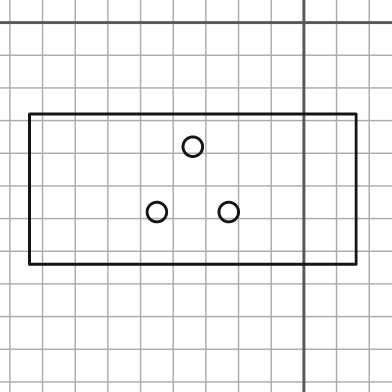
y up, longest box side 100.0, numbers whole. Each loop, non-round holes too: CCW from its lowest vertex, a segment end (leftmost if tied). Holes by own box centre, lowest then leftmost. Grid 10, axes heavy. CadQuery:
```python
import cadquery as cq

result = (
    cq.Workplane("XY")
    .moveTo(-84.0, -74.0)
    .lineTo(16.0, -74.0)
    .lineTo(16.0, -28.0)
    .lineTo(-84.0, -28.0)
    .close()
    .moveTo(-45.0, -58.0)
    .circle(3.0)
    .moveTo(-23.0, -58.0)
    .circle(3.0)
    .moveTo(-34.0, -38.0)
    .circle(3.0)
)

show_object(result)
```